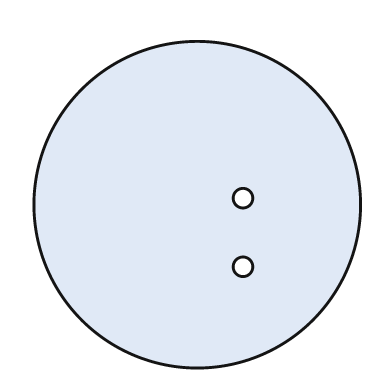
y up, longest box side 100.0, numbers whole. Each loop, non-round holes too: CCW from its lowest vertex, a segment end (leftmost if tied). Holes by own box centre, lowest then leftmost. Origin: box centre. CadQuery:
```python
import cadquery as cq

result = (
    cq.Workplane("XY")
    .moveTo(0.0, 0.0)
    .circle(50.0)
    .moveTo(14.0, -19.0)
    .circle(3.0)
    .moveTo(14.0, 2.0)
    .circle(3.0)
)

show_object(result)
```